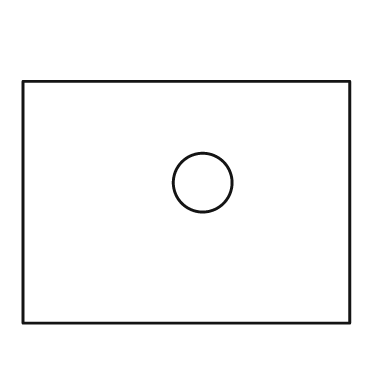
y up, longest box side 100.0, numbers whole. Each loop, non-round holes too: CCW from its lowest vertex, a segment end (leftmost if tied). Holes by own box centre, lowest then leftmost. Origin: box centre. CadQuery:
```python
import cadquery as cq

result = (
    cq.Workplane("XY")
    .moveTo(-50.0, -37.0)
    .lineTo(50.0, -37.0)
    .lineTo(50.0, 37.0)
    .lineTo(-50.0, 37.0)
    .close()
    .moveTo(5.0, 6.0)
    .circle(9.0)
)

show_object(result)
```